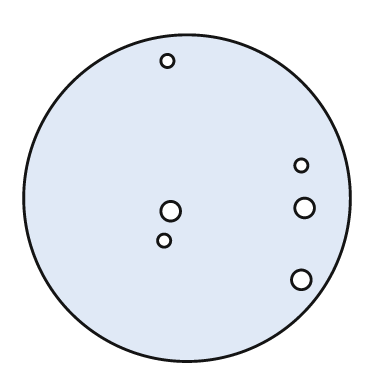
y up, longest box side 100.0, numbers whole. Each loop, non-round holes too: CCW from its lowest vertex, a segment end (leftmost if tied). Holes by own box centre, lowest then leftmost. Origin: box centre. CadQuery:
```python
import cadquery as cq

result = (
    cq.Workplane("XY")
    .moveTo(0.0, 0.0)
    .circle(50.0)
    .moveTo(35.0, -25.0)
    .circle(3.0)
    .moveTo(-7.0, -13.0)
    .circle(2.0)
    .moveTo(-5.0, -4.0)
    .circle(3.0)
    .moveTo(36.0, -3.0)
    .circle(3.0)
    .moveTo(35.0, 10.0)
    .circle(2.0)
    .moveTo(-6.0, 42.0)
    .circle(2.0)
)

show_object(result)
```